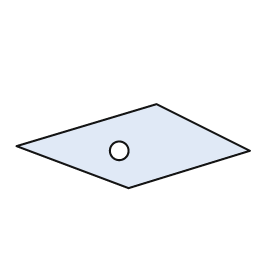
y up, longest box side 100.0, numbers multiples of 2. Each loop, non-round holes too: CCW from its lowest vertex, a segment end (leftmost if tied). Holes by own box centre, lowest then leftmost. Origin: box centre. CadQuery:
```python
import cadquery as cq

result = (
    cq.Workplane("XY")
    .moveTo(-2.0, -18.0)
    .lineTo(50.0, -2.0)
    .lineTo(10.0, 18.0)
    .lineTo(-50.0, 0.0)
    .close()
    .moveTo(-6.0, -2.0)
    .circle(4.0)
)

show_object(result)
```